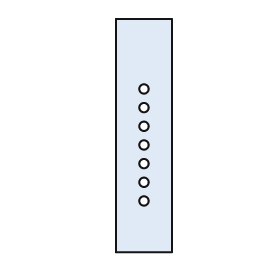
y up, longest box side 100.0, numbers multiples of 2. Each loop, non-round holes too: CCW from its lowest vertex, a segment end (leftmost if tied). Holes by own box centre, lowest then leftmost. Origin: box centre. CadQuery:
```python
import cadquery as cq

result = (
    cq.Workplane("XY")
    .moveTo(-12.0, -50.0)
    .lineTo(12.0, -50.0)
    .lineTo(12.0, 50.0)
    .lineTo(-12.0, 50.0)
    .close()
    .moveTo(0.0, -28.0)
    .circle(2.0)
    .moveTo(0.0, -20.0)
    .circle(2.0)
    .moveTo(0.0, -12.0)
    .circle(2.0)
    .moveTo(0.0, -4.0)
    .circle(2.0)
    .moveTo(0.0, 4.0)
    .circle(2.0)
    .moveTo(0.0, 12.0)
    .circle(2.0)
    .moveTo(0.0, 20.0)
    .circle(2.0)
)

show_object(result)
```